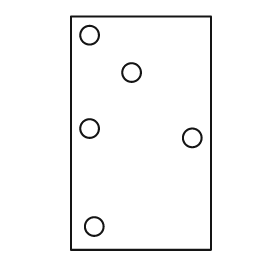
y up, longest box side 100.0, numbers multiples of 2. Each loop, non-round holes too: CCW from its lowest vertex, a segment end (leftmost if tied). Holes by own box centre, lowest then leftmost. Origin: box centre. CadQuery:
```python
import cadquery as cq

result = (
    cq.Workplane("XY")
    .moveTo(-30.0, -50.0)
    .lineTo(30.0, -50.0)
    .lineTo(30.0, 50.0)
    .lineTo(-30.0, 50.0)
    .close()
    .moveTo(-20.0, -40.0)
    .circle(4.0)
    .moveTo(22.0, -2.0)
    .circle(4.0)
    .moveTo(-22.0, 2.0)
    .circle(4.0)
    .moveTo(-4.0, 26.0)
    .circle(4.0)
    .moveTo(-22.0, 42.0)
    .circle(4.0)
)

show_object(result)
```